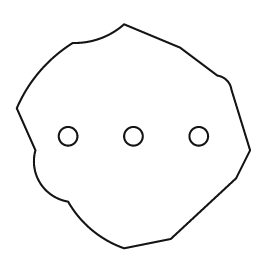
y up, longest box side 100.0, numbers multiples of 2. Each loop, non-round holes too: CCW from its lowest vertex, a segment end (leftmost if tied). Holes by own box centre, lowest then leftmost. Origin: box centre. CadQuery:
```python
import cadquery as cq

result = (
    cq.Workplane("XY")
    .moveTo(-4.0, -48.0)
    .lineTo(16.0, -44.0)
    .lineTo(44.0, -18.0)
    .lineTo(50.0, -6.0)
    .lineTo(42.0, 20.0)
    .threePointArc((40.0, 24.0), (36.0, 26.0))
    .lineTo(20.0, 38.0)
    .lineTo(-4.0, 48.0)
    .threePointArc((-14.0, 42.0), (-26.0, 40.0))
    .threePointArc((-40.0, 28.0), (-50.0, 12.0))
    .lineTo(-42.0, -6.0)
    .threePointArc((-40.0, -20.0), (-28.0, -28.0))
    .threePointArc((-18.0, -40.0), (-4.0, -48.0))
    .close()
    .moveTo(-28.0, 0.0)
    .circle(4.0)
    .moveTo(0.0, 0.0)
    .circle(4.0)
    .moveTo(28.0, 0.0)
    .circle(4.0)
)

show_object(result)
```